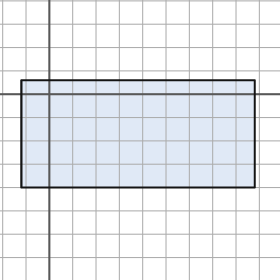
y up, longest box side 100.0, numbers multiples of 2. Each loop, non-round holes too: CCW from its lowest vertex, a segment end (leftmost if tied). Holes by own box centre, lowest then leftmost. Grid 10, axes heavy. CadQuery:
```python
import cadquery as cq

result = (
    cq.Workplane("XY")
    .moveTo(-12.0, -40.0)
    .lineTo(88.0, -40.0)
    .lineTo(88.0, 6.0)
    .lineTo(-12.0, 6.0)
    .close()
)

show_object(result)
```